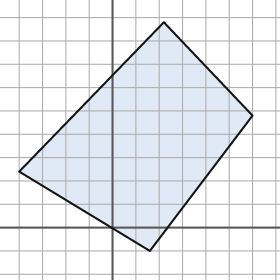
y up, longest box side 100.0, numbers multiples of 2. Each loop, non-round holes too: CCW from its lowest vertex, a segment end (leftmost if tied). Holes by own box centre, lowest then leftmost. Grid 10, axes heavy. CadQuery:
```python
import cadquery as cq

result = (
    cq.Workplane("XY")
    .moveTo(16.0, -10.0)
    .lineTo(60.0, 48.0)
    .lineTo(22.0, 88.0)
    .lineTo(-40.0, 24.0)
    .close()
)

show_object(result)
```